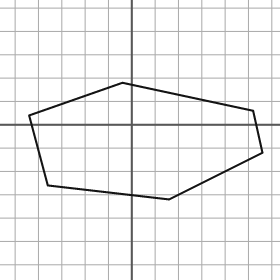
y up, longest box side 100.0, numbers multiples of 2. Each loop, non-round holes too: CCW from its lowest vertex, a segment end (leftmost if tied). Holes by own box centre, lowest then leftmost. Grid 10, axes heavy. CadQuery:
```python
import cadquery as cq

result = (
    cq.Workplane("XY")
    .moveTo(16.0, -32.0)
    .lineTo(56.0, -12.0)
    .lineTo(52.0, 6.0)
    .lineTo(-4.0, 18.0)
    .lineTo(-44.0, 4.0)
    .lineTo(-36.0, -26.0)
    .close()
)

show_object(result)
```